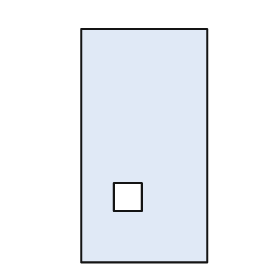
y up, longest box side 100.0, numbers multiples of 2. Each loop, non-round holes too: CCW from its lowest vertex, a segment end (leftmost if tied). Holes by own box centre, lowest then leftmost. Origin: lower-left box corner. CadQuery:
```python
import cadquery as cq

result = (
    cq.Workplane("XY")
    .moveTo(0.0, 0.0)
    .lineTo(54.0, 0.0)
    .lineTo(54.0, 100.0)
    .lineTo(0.0, 100.0)
    .close()
    .moveTo(14.0, 22.0)
    .lineTo(26.0, 22.0)
    .lineTo(26.0, 34.0)
    .lineTo(14.0, 34.0)
    .close()
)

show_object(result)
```